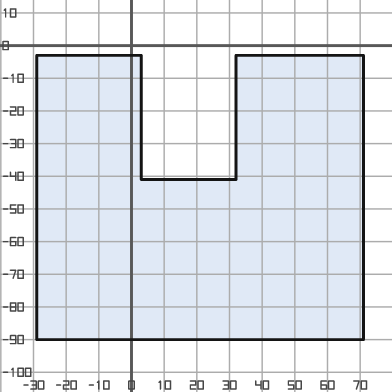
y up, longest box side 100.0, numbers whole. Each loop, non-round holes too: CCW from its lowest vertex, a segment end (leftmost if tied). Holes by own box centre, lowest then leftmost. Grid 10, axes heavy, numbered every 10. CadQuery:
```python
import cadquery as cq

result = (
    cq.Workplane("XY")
    .moveTo(-29.0, -90.0)
    .lineTo(71.0, -90.0)
    .lineTo(71.0, -3.0)
    .lineTo(32.0, -3.0)
    .lineTo(32.0, -41.0)
    .lineTo(3.0, -41.0)
    .lineTo(3.0, -3.0)
    .lineTo(-29.0, -3.0)
    .close()
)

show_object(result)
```